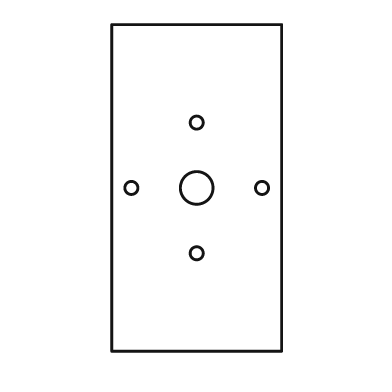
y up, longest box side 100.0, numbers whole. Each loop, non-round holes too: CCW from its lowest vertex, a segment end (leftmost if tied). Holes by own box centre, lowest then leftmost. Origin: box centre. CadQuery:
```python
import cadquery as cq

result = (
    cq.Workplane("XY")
    .moveTo(-26.0, -50.0)
    .lineTo(26.0, -50.0)
    .lineTo(26.0, 50.0)
    .lineTo(-26.0, 50.0)
    .close()
    .moveTo(0.0, -20.0)
    .circle(2.0)
    .moveTo(-20.0, 0.0)
    .circle(2.0)
    .moveTo(0.0, 0.0)
    .circle(5.0)
    .moveTo(20.0, 0.0)
    .circle(2.0)
    .moveTo(0.0, 20.0)
    .circle(2.0)
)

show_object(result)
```